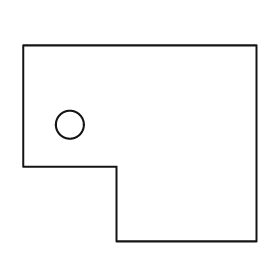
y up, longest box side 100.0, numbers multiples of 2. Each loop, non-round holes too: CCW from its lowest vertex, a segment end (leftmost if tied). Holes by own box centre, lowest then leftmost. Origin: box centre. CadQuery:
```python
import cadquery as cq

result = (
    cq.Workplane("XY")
    .moveTo(-10.0, -42.0)
    .lineTo(50.0, -42.0)
    .lineTo(50.0, 42.0)
    .lineTo(-50.0, 42.0)
    .lineTo(-50.0, -10.0)
    .lineTo(-10.0, -10.0)
    .close()
    .moveTo(-30.0, 8.0)
    .circle(6.0)
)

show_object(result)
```